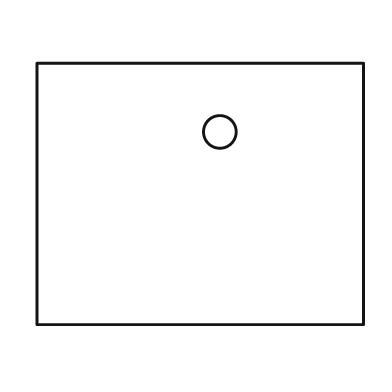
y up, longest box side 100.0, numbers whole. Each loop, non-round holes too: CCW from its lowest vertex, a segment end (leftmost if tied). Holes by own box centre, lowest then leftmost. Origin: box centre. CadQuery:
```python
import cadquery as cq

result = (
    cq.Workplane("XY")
    .moveTo(-50.0, -40.0)
    .lineTo(50.0, -40.0)
    .lineTo(50.0, 40.0)
    .lineTo(-50.0, 40.0)
    .close()
    .moveTo(6.0, 19.0)
    .circle(5.0)
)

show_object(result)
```